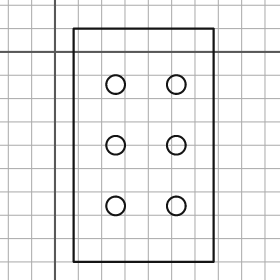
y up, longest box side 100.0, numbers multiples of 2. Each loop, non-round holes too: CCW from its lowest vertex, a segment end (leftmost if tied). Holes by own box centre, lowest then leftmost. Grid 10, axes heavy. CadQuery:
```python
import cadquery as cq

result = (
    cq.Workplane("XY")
    .moveTo(8.0, -90.0)
    .lineTo(68.0, -90.0)
    .lineTo(68.0, 10.0)
    .lineTo(8.0, 10.0)
    .close()
    .moveTo(26.0, -66.0)
    .circle(4.0)
    .moveTo(52.0, -66.0)
    .circle(4.0)
    .moveTo(26.0, -40.0)
    .circle(4.0)
    .moveTo(52.0, -40.0)
    .circle(4.0)
    .moveTo(26.0, -14.0)
    .circle(4.0)
    .moveTo(52.0, -14.0)
    .circle(4.0)
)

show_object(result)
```